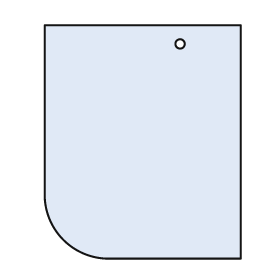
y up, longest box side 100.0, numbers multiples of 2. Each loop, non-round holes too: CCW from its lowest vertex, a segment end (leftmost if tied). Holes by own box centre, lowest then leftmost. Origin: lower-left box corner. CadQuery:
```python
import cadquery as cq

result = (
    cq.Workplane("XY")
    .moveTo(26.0, 0.0)
    .lineTo(84.0, 0.0)
    .lineTo(84.0, 100.0)
    .lineTo(0.0, 100.0)
    .lineTo(0.0, 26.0)
    .threePointArc((8.0, 8.0), (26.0, 0.0))
    .close()
    .moveTo(58.0, 92.0)
    .circle(2.0)
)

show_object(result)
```